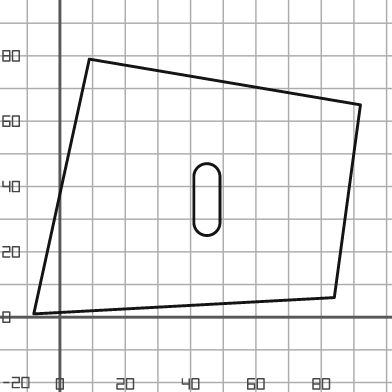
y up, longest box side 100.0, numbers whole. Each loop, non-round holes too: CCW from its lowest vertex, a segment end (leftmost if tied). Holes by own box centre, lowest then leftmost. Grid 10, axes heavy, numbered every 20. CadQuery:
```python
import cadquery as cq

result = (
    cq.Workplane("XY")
    .moveTo(-8.0, 1.0)
    .lineTo(84.0, 6.0)
    .lineTo(92.0, 65.0)
    .lineTo(9.0, 79.0)
    .close()
    .moveTo(41.0, 29.0)
    .threePointArc((45.0, 25.0), (49.0, 29.0))
    .lineTo(49.0, 43.0)
    .threePointArc((45.0, 47.0), (41.0, 43.0))
    .close()
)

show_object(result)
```